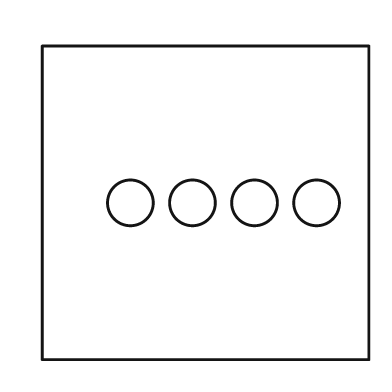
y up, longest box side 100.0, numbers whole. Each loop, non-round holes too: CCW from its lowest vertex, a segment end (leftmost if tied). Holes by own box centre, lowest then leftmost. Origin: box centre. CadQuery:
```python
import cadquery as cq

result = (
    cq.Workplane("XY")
    .moveTo(-50.0, -48.0)
    .lineTo(50.0, -48.0)
    .lineTo(50.0, 48.0)
    .lineTo(-50.0, 48.0)
    .close()
    .moveTo(-23.0, 0.0)
    .circle(7.0)
    .moveTo(-4.0, 0.0)
    .circle(7.0)
    .moveTo(15.0, 0.0)
    .circle(7.0)
    .moveTo(34.0, 0.0)
    .circle(7.0)
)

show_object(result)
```